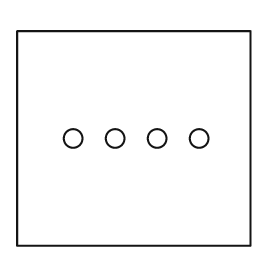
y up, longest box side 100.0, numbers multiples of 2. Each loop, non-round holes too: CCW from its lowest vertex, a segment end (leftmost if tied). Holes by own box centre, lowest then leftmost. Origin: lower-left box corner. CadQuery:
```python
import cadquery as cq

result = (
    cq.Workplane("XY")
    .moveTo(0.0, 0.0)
    .lineTo(100.0, 0.0)
    .lineTo(100.0, 92.0)
    .lineTo(0.0, 92.0)
    .close()
    .moveTo(24.0, 46.0)
    .circle(4.0)
    .moveTo(42.0, 46.0)
    .circle(4.0)
    .moveTo(60.0, 46.0)
    .circle(4.0)
    .moveTo(78.0, 46.0)
    .circle(4.0)
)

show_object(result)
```